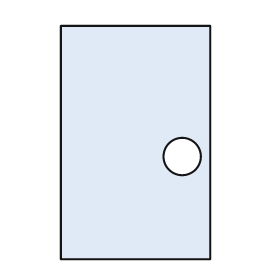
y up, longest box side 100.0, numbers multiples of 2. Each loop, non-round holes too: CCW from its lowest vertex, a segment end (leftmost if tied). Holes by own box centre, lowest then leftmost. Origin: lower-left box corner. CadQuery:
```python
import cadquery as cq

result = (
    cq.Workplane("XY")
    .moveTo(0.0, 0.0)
    .lineTo(64.0, 0.0)
    .lineTo(64.0, 100.0)
    .lineTo(0.0, 100.0)
    .close()
    .moveTo(52.0, 44.0)
    .circle(8.0)
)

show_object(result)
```